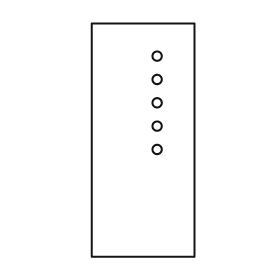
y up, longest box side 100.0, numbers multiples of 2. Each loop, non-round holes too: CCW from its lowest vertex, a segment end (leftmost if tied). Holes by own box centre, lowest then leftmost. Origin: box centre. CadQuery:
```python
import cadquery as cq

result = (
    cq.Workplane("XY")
    .moveTo(-22.0, -50.0)
    .lineTo(22.0, -50.0)
    .lineTo(22.0, 50.0)
    .lineTo(-22.0, 50.0)
    .close()
    .moveTo(6.0, -4.0)
    .circle(2.0)
    .moveTo(6.0, 6.0)
    .circle(2.0)
    .moveTo(6.0, 16.0)
    .circle(2.0)
    .moveTo(6.0, 26.0)
    .circle(2.0)
    .moveTo(6.0, 36.0)
    .circle(2.0)
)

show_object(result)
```